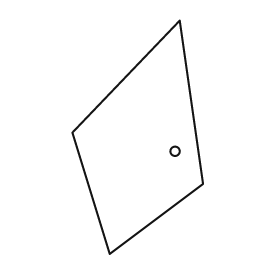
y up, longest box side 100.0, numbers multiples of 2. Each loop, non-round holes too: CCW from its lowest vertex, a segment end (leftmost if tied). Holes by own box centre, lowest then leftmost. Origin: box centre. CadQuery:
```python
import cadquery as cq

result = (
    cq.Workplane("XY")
    .moveTo(-12.0, -50.0)
    .lineTo(28.0, -20.0)
    .lineTo(18.0, 50.0)
    .lineTo(-28.0, 2.0)
    .close()
    .moveTo(16.0, -6.0)
    .circle(2.0)
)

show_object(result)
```